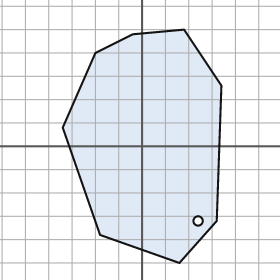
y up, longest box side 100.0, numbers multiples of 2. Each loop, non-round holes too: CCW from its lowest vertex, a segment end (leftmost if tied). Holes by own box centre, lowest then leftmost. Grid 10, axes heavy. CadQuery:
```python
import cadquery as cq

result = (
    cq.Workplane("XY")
    .moveTo(16.0, -50.0)
    .lineTo(32.0, -32.0)
    .lineTo(34.0, 26.0)
    .lineTo(18.0, 50.0)
    .lineTo(-4.0, 48.0)
    .lineTo(-20.0, 40.0)
    .lineTo(-34.0, 8.0)
    .lineTo(-18.0, -38.0)
    .close()
    .moveTo(24.0, -32.0)
    .circle(2.0)
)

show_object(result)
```